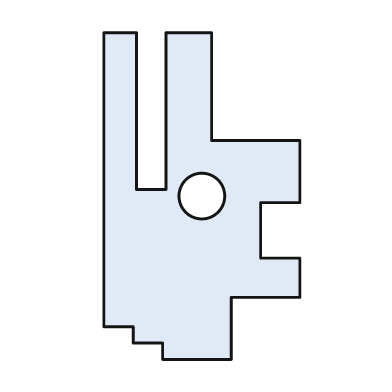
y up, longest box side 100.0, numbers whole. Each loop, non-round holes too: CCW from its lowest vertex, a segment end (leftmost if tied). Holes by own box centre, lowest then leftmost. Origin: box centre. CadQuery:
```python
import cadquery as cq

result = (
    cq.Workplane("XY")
    .moveTo(-12.0, -50.0)
    .lineTo(9.0, -50.0)
    .lineTo(9.0, -31.0)
    .lineTo(30.0, -31.0)
    .lineTo(30.0, -19.0)
    .lineTo(18.0, -19.0)
    .lineTo(18.0, -2.0)
    .lineTo(30.0, -2.0)
    .lineTo(30.0, 17.0)
    .lineTo(3.0, 17.0)
    .lineTo(3.0, 50.0)
    .lineTo(-11.0, 50.0)
    .lineTo(-11.0, 2.0)
    .lineTo(-20.0, 2.0)
    .lineTo(-20.0, 50.0)
    .lineTo(-30.0, 50.0)
    .lineTo(-30.0, -40.0)
    .lineTo(-21.0, -40.0)
    .lineTo(-21.0, -45.0)
    .lineTo(-12.0, -45.0)
    .close()
    .moveTo(0.0, 0.0)
    .circle(7.0)
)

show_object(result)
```